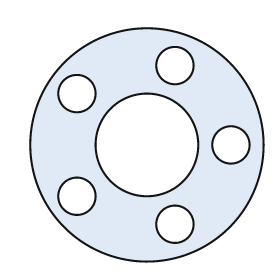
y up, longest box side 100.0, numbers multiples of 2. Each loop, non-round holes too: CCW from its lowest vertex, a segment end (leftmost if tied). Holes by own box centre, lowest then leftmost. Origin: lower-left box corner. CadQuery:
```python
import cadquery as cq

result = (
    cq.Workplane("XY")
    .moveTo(50.0, 50.0)
    .circle(50.0)
    .moveTo(62.0, 16.0)
    .circle(8.0)
    .moveTo(20.0, 28.0)
    .circle(8.0)
    .moveTo(50.0, 50.0)
    .circle(22.0)
    .moveTo(86.0, 50.0)
    .circle(8.0)
    .moveTo(20.0, 72.0)
    .circle(8.0)
    .moveTo(62.0, 84.0)
    .circle(8.0)
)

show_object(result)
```